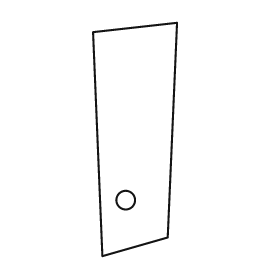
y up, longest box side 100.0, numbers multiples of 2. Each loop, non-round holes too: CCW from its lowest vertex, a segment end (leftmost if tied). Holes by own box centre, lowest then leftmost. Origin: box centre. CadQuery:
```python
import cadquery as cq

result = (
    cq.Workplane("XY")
    .moveTo(-14.0, -50.0)
    .lineTo(14.0, -42.0)
    .lineTo(18.0, 50.0)
    .lineTo(-18.0, 46.0)
    .close()
    .moveTo(-4.0, -26.0)
    .circle(4.0)
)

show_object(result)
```